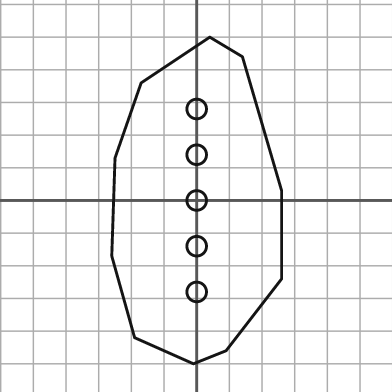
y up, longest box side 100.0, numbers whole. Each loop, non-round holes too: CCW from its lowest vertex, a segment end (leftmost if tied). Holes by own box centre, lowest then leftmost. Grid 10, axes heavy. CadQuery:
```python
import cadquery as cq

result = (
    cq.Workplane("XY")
    .moveTo(-1.0, -50.0)
    .lineTo(9.0, -46.0)
    .lineTo(26.0, -24.0)
    .lineTo(26.0, 3.0)
    .lineTo(14.0, 44.0)
    .lineTo(4.0, 50.0)
    .lineTo(-17.0, 36.0)
    .lineTo(-25.0, 13.0)
    .lineTo(-26.0, -17.0)
    .lineTo(-19.0, -42.0)
    .close()
    .moveTo(0.0, -28.0)
    .circle(3.0)
    .moveTo(0.0, -14.0)
    .circle(3.0)
    .moveTo(0.0, 0.0)
    .circle(3.0)
    .moveTo(0.0, 14.0)
    .circle(3.0)
    .moveTo(0.0, 28.0)
    .circle(3.0)
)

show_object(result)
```